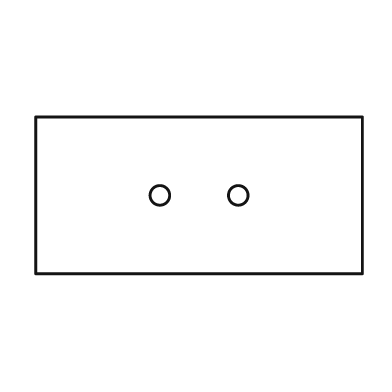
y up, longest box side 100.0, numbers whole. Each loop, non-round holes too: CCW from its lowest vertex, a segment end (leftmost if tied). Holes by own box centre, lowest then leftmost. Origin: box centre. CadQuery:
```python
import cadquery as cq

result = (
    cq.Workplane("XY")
    .moveTo(-50.0, -24.0)
    .lineTo(50.0, -24.0)
    .lineTo(50.0, 24.0)
    .lineTo(-50.0, 24.0)
    .close()
    .moveTo(-12.0, 0.0)
    .circle(3.0)
    .moveTo(12.0, 0.0)
    .circle(3.0)
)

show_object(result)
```